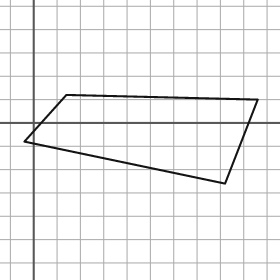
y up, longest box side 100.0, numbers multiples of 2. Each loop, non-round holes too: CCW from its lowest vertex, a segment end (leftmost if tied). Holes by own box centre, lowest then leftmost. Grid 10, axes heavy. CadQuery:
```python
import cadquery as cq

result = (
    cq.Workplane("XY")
    .moveTo(82.0, -26.0)
    .lineTo(96.0, 10.0)
    .lineTo(14.0, 12.0)
    .lineTo(-4.0, -8.0)
    .close()
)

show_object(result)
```